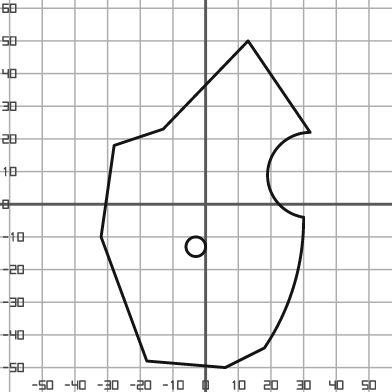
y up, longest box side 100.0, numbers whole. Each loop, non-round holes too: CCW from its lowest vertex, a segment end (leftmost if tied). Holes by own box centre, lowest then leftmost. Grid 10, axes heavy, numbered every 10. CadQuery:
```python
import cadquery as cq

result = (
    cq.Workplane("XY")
    .moveTo(6.0, -50.0)
    .lineTo(18.0, -44.0)
    .threePointArc((27.0, -25.0), (30.0, -4.0))
    .threePointArc((19.0, 10.0), (32.0, 22.0))
    .lineTo(13.0, 50.0)
    .lineTo(-13.0, 23.0)
    .lineTo(-28.0, 18.0)
    .lineTo(-32.0, -10.0)
    .lineTo(-18.0, -48.0)
    .close()
    .moveTo(-3.0, -13.0)
    .circle(3.0)
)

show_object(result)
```